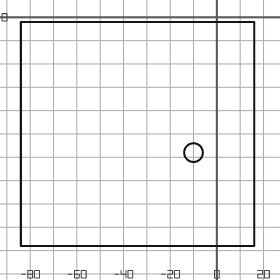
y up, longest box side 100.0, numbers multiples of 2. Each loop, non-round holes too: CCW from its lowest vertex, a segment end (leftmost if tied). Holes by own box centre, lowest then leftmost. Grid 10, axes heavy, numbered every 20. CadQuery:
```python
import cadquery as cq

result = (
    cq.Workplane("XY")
    .moveTo(-84.0, -98.0)
    .lineTo(16.0, -98.0)
    .lineTo(16.0, -2.0)
    .lineTo(-84.0, -2.0)
    .close()
    .moveTo(-10.0, -58.0)
    .circle(4.0)
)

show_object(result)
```